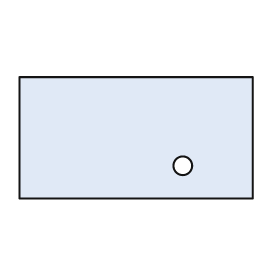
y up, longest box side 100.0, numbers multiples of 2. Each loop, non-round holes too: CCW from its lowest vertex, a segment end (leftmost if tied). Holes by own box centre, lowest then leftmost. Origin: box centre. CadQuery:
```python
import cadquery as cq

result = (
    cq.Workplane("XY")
    .moveTo(-50.0, -26.0)
    .lineTo(50.0, -26.0)
    .lineTo(50.0, 26.0)
    .lineTo(-50.0, 26.0)
    .close()
    .moveTo(20.0, -12.0)
    .circle(4.0)
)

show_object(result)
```